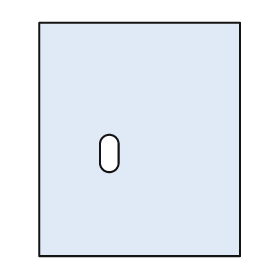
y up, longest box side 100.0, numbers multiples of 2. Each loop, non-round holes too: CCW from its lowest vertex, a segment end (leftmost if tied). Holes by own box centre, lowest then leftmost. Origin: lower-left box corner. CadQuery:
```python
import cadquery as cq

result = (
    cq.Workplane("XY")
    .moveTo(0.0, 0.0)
    .lineTo(86.0, 0.0)
    .lineTo(86.0, 100.0)
    .lineTo(0.0, 100.0)
    .close()
    .moveTo(26.0, 40.0)
    .threePointArc((30.0, 36.0), (34.0, 40.0))
    .lineTo(34.0, 48.0)
    .threePointArc((30.0, 52.0), (26.0, 48.0))
    .close()
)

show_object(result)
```